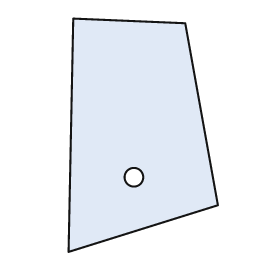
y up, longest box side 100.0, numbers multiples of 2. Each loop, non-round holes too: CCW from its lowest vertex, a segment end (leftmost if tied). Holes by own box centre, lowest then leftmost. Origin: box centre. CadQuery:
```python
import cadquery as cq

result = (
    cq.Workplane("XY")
    .moveTo(-32.0, -50.0)
    .lineTo(32.0, -30.0)
    .lineTo(18.0, 48.0)
    .lineTo(-30.0, 50.0)
    .close()
    .moveTo(-4.0, -18.0)
    .circle(4.0)
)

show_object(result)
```